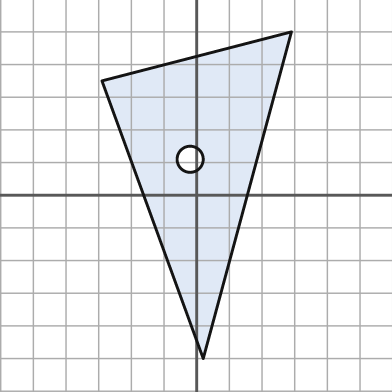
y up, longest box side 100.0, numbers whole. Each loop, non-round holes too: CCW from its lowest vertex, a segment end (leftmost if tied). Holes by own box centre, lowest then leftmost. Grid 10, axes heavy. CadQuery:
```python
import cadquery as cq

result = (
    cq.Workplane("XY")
    .moveTo(2.0, -50.0)
    .lineTo(29.0, 50.0)
    .lineTo(-29.0, 35.0)
    .close()
    .moveTo(-2.0, 11.0)
    .circle(4.0)
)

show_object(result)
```